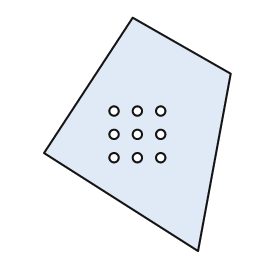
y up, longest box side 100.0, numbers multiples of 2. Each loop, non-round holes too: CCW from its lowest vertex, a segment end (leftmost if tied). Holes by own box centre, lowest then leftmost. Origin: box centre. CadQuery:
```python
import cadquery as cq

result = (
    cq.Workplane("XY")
    .moveTo(26.0, -50.0)
    .lineTo(40.0, 26.0)
    .lineTo(-2.0, 50.0)
    .lineTo(-40.0, -8.0)
    .close()
    .moveTo(-10.0, -10.0)
    .circle(2.0)
    .moveTo(0.0, -10.0)
    .circle(2.0)
    .moveTo(10.0, -10.0)
    .circle(2.0)
    .moveTo(-10.0, 0.0)
    .circle(2.0)
    .moveTo(0.0, 0.0)
    .circle(2.0)
    .moveTo(10.0, 0.0)
    .circle(2.0)
    .moveTo(-10.0, 10.0)
    .circle(2.0)
    .moveTo(0.0, 10.0)
    .circle(2.0)
    .moveTo(10.0, 10.0)
    .circle(2.0)
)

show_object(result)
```